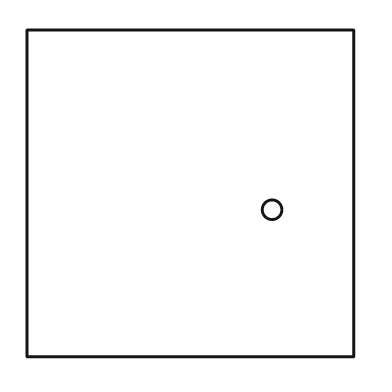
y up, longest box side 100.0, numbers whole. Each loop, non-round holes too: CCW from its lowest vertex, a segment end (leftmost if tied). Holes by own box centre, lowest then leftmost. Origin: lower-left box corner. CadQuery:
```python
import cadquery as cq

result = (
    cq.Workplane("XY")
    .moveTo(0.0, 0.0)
    .lineTo(100.0, 0.0)
    .lineTo(100.0, 100.0)
    .lineTo(0.0, 100.0)
    .close()
    .moveTo(75.0, 45.0)
    .circle(3.0)
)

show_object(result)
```